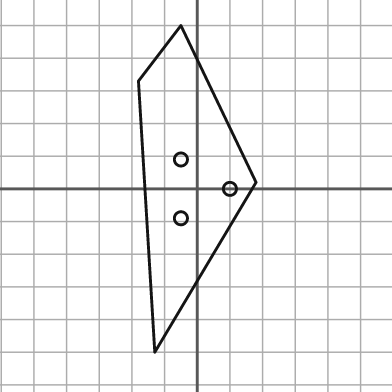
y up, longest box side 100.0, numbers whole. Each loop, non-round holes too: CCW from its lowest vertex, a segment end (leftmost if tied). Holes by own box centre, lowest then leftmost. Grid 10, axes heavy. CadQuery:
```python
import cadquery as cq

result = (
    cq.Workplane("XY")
    .moveTo(-13.0, -50.0)
    .lineTo(18.0, 2.0)
    .lineTo(-5.0, 50.0)
    .lineTo(-18.0, 33.0)
    .close()
    .moveTo(-5.0, -9.0)
    .circle(2.0)
    .moveTo(10.0, 0.0)
    .circle(2.0)
    .moveTo(-5.0, 9.0)
    .circle(2.0)
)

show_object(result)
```